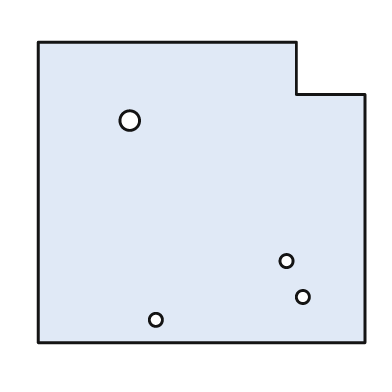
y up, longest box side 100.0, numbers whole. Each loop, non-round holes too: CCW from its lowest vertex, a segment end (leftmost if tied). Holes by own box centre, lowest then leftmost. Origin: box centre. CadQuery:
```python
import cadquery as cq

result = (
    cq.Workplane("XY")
    .moveTo(-50.0, -46.0)
    .lineTo(50.0, -46.0)
    .lineTo(50.0, 30.0)
    .lineTo(29.0, 30.0)
    .lineTo(29.0, 46.0)
    .lineTo(-50.0, 46.0)
    .close()
    .moveTo(-14.0, -39.0)
    .circle(2.0)
    .moveTo(31.0, -32.0)
    .circle(2.0)
    .moveTo(26.0, -21.0)
    .circle(2.0)
    .moveTo(-22.0, 22.0)
    .circle(3.0)
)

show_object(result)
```